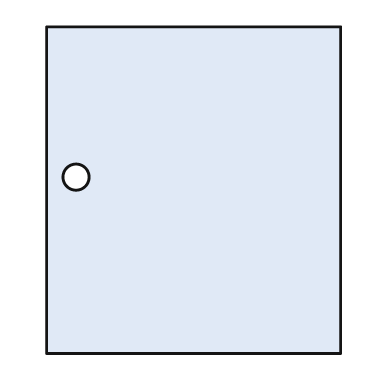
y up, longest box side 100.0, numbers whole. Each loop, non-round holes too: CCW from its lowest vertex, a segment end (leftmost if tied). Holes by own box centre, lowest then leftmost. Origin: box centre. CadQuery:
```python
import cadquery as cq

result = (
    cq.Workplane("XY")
    .moveTo(-45.0, -50.0)
    .lineTo(45.0, -50.0)
    .lineTo(45.0, 50.0)
    .lineTo(-45.0, 50.0)
    .close()
    .moveTo(-36.0, 4.0)
    .circle(4.0)
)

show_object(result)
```